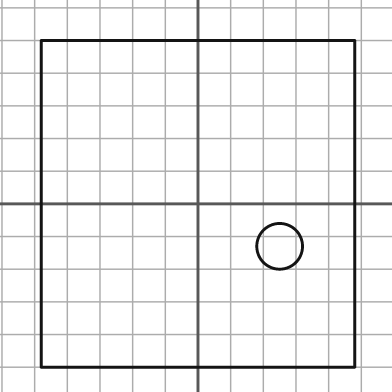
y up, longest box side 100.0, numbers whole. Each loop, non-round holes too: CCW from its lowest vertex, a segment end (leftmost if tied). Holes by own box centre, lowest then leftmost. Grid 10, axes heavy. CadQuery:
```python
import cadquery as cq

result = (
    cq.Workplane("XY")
    .moveTo(-48.0, -50.0)
    .lineTo(48.0, -50.0)
    .lineTo(48.0, 50.0)
    .lineTo(-48.0, 50.0)
    .close()
    .moveTo(25.0, -13.0)
    .circle(7.0)
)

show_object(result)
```